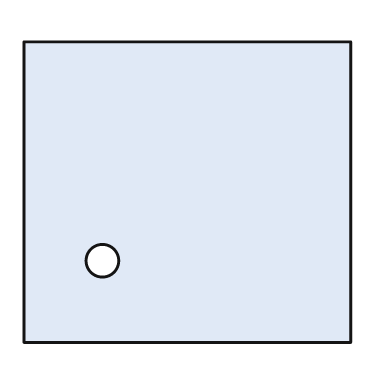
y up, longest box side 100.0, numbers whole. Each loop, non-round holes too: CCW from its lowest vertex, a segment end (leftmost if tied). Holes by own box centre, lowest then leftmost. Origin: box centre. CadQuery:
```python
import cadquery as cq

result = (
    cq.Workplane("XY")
    .moveTo(-50.0, -46.0)
    .lineTo(50.0, -46.0)
    .lineTo(50.0, 46.0)
    .lineTo(-50.0, 46.0)
    .close()
    .moveTo(-26.0, -21.0)
    .circle(5.0)
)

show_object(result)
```